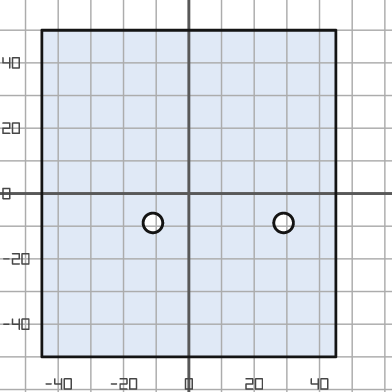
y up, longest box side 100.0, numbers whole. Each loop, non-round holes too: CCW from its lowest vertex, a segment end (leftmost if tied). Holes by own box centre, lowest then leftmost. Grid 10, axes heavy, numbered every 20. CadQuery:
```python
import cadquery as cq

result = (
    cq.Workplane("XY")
    .moveTo(-45.0, -50.0)
    .lineTo(45.0, -50.0)
    .lineTo(45.0, 50.0)
    .lineTo(-45.0, 50.0)
    .close()
    .moveTo(-11.0, -9.0)
    .circle(3.0)
    .moveTo(29.0, -9.0)
    .circle(3.0)
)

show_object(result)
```